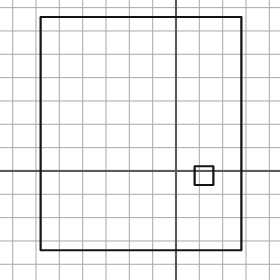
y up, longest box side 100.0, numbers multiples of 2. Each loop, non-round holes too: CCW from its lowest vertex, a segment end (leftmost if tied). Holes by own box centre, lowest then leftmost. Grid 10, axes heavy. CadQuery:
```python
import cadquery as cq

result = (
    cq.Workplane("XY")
    .moveTo(-58.0, -34.0)
    .lineTo(28.0, -34.0)
    .lineTo(28.0, 66.0)
    .lineTo(-58.0, 66.0)
    .close()
    .moveTo(8.0, -6.0)
    .lineTo(16.0, -6.0)
    .lineTo(16.0, 2.0)
    .lineTo(8.0, 2.0)
    .close()
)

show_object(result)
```